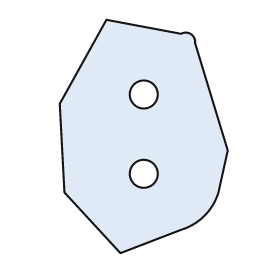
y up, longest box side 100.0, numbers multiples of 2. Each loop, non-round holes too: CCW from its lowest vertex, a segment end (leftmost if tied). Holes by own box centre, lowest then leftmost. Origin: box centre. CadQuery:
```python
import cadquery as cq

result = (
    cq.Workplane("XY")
    .moveTo(-10.0, -50.0)
    .lineTo(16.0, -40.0)
    .threePointArc((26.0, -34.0), (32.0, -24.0))
    .lineTo(36.0, -6.0)
    .lineTo(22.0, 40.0)
    .threePointArc((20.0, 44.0), (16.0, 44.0))
    .lineTo(-16.0, 50.0)
    .lineTo(-36.0, 14.0)
    .lineTo(-34.0, -24.0)
    .close()
    .moveTo(0.0, -16.0)
    .circle(6.0)
    .moveTo(0.0, 18.0)
    .circle(6.0)
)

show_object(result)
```